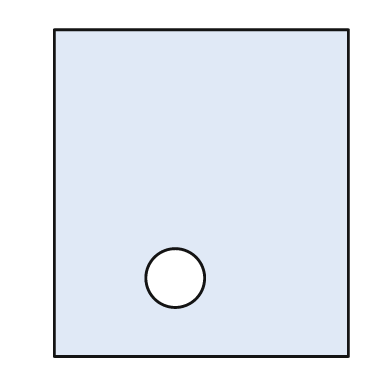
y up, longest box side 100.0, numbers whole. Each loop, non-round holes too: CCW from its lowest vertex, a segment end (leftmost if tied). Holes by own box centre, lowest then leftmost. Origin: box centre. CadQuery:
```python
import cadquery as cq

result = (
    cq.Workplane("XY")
    .moveTo(-45.0, -50.0)
    .lineTo(45.0, -50.0)
    .lineTo(45.0, 50.0)
    .lineTo(-45.0, 50.0)
    .close()
    .moveTo(-8.0, -26.0)
    .circle(9.0)
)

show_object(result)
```